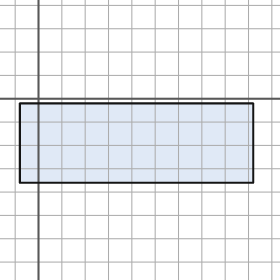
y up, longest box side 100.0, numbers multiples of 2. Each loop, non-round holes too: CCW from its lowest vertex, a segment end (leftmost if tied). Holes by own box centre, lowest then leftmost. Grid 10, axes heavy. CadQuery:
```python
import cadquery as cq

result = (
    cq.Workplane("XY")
    .moveTo(-8.0, -36.0)
    .lineTo(92.0, -36.0)
    .lineTo(92.0, -2.0)
    .lineTo(-8.0, -2.0)
    .close()
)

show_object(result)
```